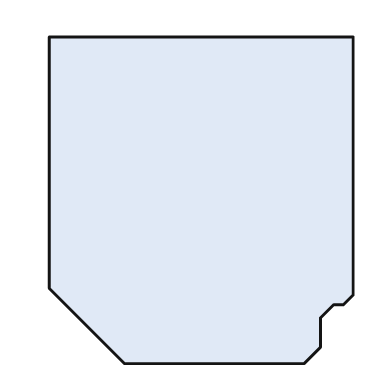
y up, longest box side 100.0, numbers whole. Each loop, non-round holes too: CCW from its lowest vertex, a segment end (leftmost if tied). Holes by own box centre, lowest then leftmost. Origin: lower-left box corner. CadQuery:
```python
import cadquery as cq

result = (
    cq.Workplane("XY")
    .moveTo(23.0, 0.0)
    .lineTo(78.0, 0.0)
    .lineTo(83.0, 5.0)
    .lineTo(83.0, 14.0)
    .lineTo(87.0, 18.0)
    .lineTo(90.0, 18.0)
    .lineTo(93.0, 21.0)
    .lineTo(93.0, 100.0)
    .lineTo(0.0, 100.0)
    .lineTo(0.0, 23.0)
    .close()
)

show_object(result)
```